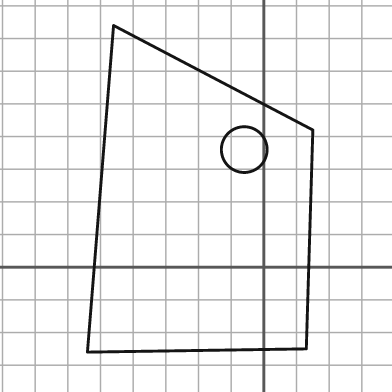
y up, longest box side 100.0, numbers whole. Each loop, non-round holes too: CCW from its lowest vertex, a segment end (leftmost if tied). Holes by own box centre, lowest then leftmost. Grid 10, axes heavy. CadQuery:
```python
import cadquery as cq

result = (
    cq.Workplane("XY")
    .moveTo(-54.0, -26.0)
    .lineTo(13.0, -25.0)
    .lineTo(15.0, 42.0)
    .lineTo(-46.0, 74.0)
    .close()
    .moveTo(-6.0, 36.0)
    .circle(7.0)
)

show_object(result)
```